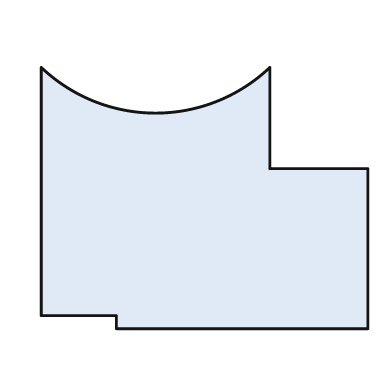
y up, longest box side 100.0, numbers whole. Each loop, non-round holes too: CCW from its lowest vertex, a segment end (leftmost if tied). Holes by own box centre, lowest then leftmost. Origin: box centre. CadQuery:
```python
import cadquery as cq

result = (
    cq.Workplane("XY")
    .moveTo(-27.0, -40.0)
    .lineTo(50.0, -40.0)
    .lineTo(50.0, 9.0)
    .lineTo(20.0, 9.0)
    .lineTo(20.0, 40.0)
    .threePointArc((-15.0, 26.0), (-50.0, 40.0))
    .lineTo(-50.0, -36.0)
    .lineTo(-27.0, -36.0)
    .close()
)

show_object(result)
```